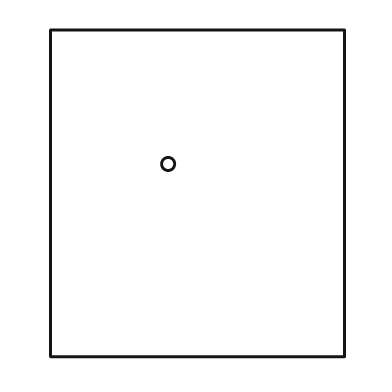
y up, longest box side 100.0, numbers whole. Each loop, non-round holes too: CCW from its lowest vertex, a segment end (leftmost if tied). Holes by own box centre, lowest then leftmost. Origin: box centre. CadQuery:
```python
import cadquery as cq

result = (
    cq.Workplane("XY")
    .moveTo(-45.0, -50.0)
    .lineTo(45.0, -50.0)
    .lineTo(45.0, 50.0)
    .lineTo(-45.0, 50.0)
    .close()
    .moveTo(-9.0, 9.0)
    .circle(2.0)
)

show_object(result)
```